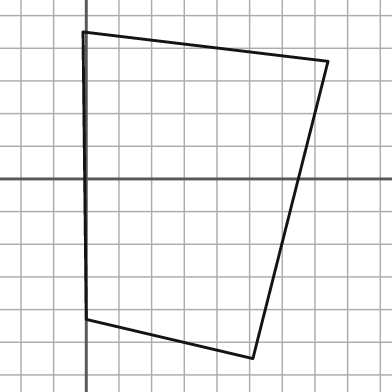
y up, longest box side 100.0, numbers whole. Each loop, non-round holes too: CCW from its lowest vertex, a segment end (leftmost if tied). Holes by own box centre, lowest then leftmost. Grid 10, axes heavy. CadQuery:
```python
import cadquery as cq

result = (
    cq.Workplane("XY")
    .moveTo(51.0, -55.0)
    .lineTo(74.0, 36.0)
    .lineTo(-1.0, 45.0)
    .lineTo(0.0, -43.0)
    .close()
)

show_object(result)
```